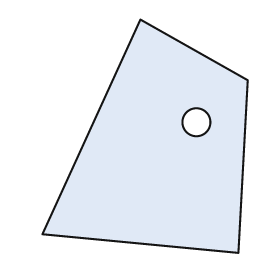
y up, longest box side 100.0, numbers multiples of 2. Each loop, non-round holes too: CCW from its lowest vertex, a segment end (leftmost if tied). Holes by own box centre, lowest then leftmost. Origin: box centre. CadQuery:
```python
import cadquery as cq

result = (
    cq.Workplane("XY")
    .moveTo(40.0, -50.0)
    .lineTo(44.0, 24.0)
    .lineTo(-2.0, 50.0)
    .lineTo(-44.0, -42.0)
    .close()
    .moveTo(22.0, 6.0)
    .circle(6.0)
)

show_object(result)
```